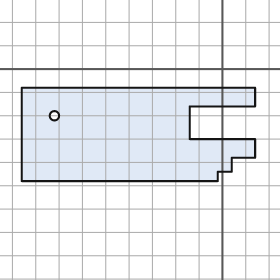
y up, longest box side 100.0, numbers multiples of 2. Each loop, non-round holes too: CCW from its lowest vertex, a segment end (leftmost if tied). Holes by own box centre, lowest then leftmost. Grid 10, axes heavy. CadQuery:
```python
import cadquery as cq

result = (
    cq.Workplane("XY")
    .moveTo(-86.0, -48.0)
    .lineTo(-2.0, -48.0)
    .lineTo(-2.0, -44.0)
    .lineTo(4.0, -44.0)
    .lineTo(4.0, -38.0)
    .lineTo(14.0, -38.0)
    .lineTo(14.0, -30.0)
    .lineTo(-14.0, -30.0)
    .lineTo(-14.0, -16.0)
    .lineTo(14.0, -16.0)
    .lineTo(14.0, -8.0)
    .lineTo(-86.0, -8.0)
    .close()
    .moveTo(-72.0, -20.0)
    .circle(2.0)
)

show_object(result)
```